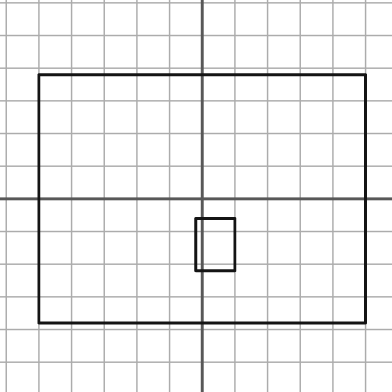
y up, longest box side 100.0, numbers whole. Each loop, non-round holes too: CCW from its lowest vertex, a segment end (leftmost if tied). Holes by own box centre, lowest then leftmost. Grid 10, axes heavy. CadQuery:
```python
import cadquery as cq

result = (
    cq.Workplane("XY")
    .moveTo(-50.0, -38.0)
    .lineTo(50.0, -38.0)
    .lineTo(50.0, 38.0)
    .lineTo(-50.0, 38.0)
    .close()
    .moveTo(-2.0, -22.0)
    .lineTo(10.0, -22.0)
    .lineTo(10.0, -6.0)
    .lineTo(-2.0, -6.0)
    .close()
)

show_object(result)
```